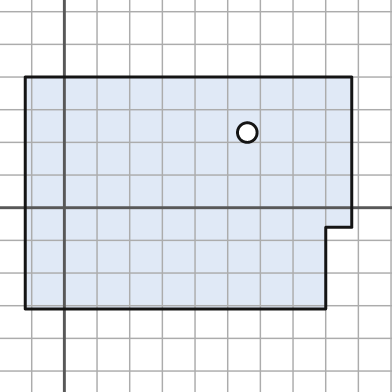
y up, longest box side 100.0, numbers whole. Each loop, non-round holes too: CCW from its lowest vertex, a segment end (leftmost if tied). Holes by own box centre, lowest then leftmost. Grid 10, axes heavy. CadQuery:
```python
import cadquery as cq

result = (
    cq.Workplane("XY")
    .moveTo(-12.0, -31.0)
    .lineTo(80.0, -31.0)
    .lineTo(80.0, -6.0)
    .lineTo(88.0, -6.0)
    .lineTo(88.0, 40.0)
    .lineTo(-12.0, 40.0)
    .close()
    .moveTo(56.0, 23.0)
    .circle(3.0)
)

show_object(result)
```